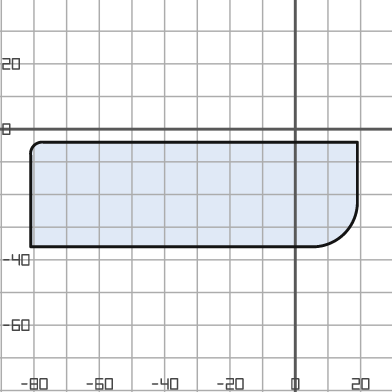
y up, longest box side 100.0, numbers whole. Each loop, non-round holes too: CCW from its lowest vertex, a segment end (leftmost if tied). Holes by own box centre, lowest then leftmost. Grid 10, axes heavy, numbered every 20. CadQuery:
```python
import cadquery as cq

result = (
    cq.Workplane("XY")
    .moveTo(-81.0, -36.0)
    .lineTo(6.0, -36.0)
    .threePointArc((15.0, -32.0), (19.0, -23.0))
    .lineTo(19.0, -4.0)
    .lineTo(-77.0, -4.0)
    .threePointArc((-80.0, -5.0), (-81.0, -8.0))
    .close()
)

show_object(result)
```